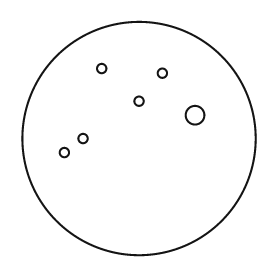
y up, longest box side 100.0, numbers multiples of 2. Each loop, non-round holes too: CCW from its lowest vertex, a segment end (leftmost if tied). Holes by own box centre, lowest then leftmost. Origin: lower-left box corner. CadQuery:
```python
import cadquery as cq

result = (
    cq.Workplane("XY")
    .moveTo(50.0, 50.0)
    .circle(50.0)
    .moveTo(18.0, 44.0)
    .circle(2.0)
    .moveTo(26.0, 50.0)
    .circle(2.0)
    .moveTo(74.0, 60.0)
    .circle(4.0)
    .moveTo(50.0, 66.0)
    .circle(2.0)
    .moveTo(60.0, 78.0)
    .circle(2.0)
    .moveTo(34.0, 80.0)
    .circle(2.0)
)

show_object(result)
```